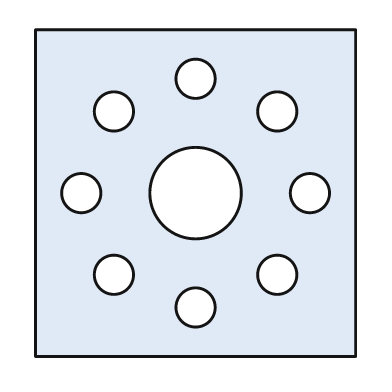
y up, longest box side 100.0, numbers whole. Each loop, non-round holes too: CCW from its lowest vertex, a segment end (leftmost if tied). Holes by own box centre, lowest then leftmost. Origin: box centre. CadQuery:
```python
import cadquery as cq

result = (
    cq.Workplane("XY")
    .moveTo(-49.0, -50.0)
    .lineTo(49.0, -50.0)
    .lineTo(49.0, 50.0)
    .lineTo(-49.0, 50.0)
    .close()
    .moveTo(0.0, -35.0)
    .circle(6.0)
    .moveTo(-25.0, -25.0)
    .circle(6.0)
    .moveTo(25.0, -25.0)
    .circle(6.0)
    .moveTo(-35.0, 0.0)
    .circle(6.0)
    .moveTo(0.0, 0.0)
    .circle(14.0)
    .moveTo(35.0, 0.0)
    .circle(6.0)
    .moveTo(-25.0, 25.0)
    .circle(6.0)
    .moveTo(25.0, 25.0)
    .circle(6.0)
    .moveTo(0.0, 35.0)
    .circle(6.0)
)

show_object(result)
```